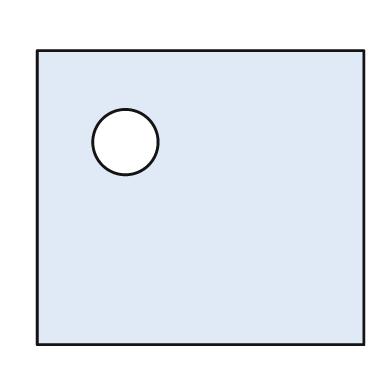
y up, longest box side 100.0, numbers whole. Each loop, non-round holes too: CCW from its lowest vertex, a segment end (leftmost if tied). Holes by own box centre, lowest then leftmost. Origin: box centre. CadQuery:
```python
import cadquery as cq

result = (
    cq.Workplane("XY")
    .moveTo(-50.0, -45.0)
    .lineTo(50.0, -45.0)
    .lineTo(50.0, 45.0)
    .lineTo(-50.0, 45.0)
    .close()
    .moveTo(-23.0, 17.0)
    .circle(10.0)
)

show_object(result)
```